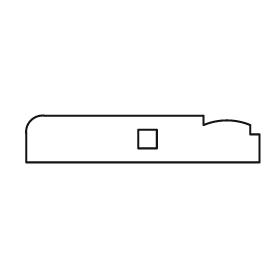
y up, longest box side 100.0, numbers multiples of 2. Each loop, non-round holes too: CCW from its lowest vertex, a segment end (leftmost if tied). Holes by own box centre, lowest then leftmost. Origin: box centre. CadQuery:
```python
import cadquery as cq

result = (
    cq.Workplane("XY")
    .moveTo(-50.0, -10.0)
    .lineTo(50.0, -10.0)
    .lineTo(50.0, 2.0)
    .lineTo(46.0, 2.0)
    .lineTo(46.0, 6.0)
    .threePointArc((36.0, 8.0), (26.0, 6.0))
    .lineTo(26.0, 10.0)
    .lineTo(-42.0, 10.0)
    .threePointArc((-48.0, 8.0), (-50.0, 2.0))
    .close()
    .moveTo(-2.0, -4.0)
    .lineTo(6.0, -4.0)
    .lineTo(6.0, 4.0)
    .lineTo(-2.0, 4.0)
    .close()
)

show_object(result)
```